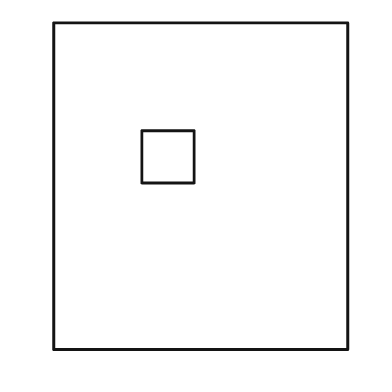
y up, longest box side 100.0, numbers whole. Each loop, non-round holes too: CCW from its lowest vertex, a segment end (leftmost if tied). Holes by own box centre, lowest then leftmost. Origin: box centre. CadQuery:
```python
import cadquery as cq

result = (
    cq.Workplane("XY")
    .moveTo(-45.0, -50.0)
    .lineTo(45.0, -50.0)
    .lineTo(45.0, 50.0)
    .lineTo(-45.0, 50.0)
    .close()
    .moveTo(-18.0, 1.0)
    .lineTo(-2.0, 1.0)
    .lineTo(-2.0, 17.0)
    .lineTo(-18.0, 17.0)
    .close()
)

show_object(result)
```